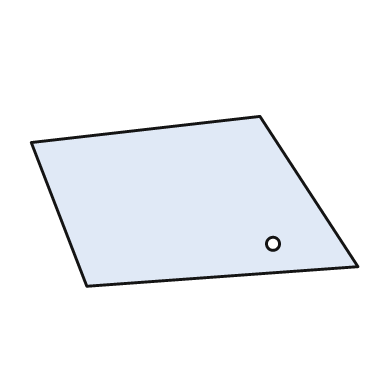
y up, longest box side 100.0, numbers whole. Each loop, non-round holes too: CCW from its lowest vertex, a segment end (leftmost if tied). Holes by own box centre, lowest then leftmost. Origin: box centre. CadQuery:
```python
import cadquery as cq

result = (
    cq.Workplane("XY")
    .moveTo(-33.0, -26.0)
    .lineTo(50.0, -20.0)
    .lineTo(20.0, 26.0)
    .lineTo(-50.0, 18.0)
    .close()
    .moveTo(24.0, -13.0)
    .circle(2.0)
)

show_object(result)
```